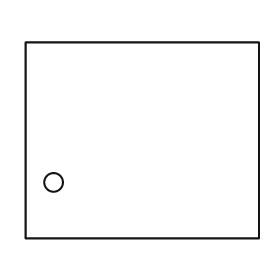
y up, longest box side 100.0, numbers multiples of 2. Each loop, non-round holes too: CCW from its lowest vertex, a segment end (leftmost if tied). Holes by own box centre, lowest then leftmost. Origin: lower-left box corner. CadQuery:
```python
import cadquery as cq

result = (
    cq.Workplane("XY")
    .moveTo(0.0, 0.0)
    .lineTo(100.0, 0.0)
    .lineTo(100.0, 84.0)
    .lineTo(0.0, 84.0)
    .close()
    .moveTo(12.0, 24.0)
    .circle(4.0)
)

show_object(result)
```